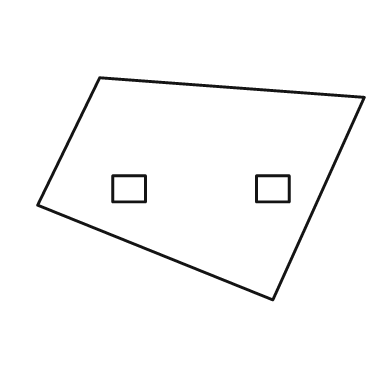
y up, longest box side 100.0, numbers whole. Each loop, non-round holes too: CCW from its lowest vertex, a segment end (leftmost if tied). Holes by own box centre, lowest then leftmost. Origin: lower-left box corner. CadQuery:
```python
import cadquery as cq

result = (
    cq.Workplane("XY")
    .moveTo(72.0, 0.0)
    .lineTo(100.0, 62.0)
    .lineTo(19.0, 68.0)
    .lineTo(0.0, 29.0)
    .close()
    .moveTo(23.0, 30.0)
    .lineTo(33.0, 30.0)
    .lineTo(33.0, 38.0)
    .lineTo(23.0, 38.0)
    .close()
    .moveTo(67.0, 30.0)
    .lineTo(77.0, 30.0)
    .lineTo(77.0, 38.0)
    .lineTo(67.0, 38.0)
    .close()
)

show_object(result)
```